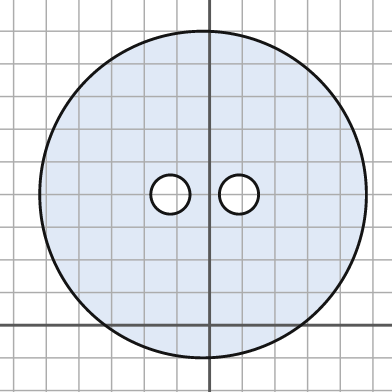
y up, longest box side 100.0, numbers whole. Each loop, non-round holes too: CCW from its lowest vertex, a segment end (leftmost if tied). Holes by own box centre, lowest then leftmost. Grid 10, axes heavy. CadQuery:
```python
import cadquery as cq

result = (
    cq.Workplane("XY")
    .moveTo(-2.0, 40.0)
    .circle(50.0)
    .moveTo(-12.0, 40.0)
    .circle(6.0)
    .moveTo(9.0, 40.0)
    .circle(6.0)
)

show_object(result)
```